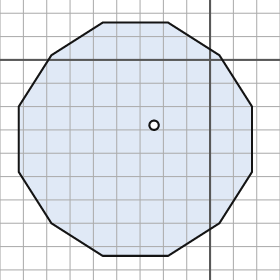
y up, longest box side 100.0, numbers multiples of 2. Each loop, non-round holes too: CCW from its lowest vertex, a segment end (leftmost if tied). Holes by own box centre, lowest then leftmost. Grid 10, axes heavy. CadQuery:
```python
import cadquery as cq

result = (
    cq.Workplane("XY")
    .moveTo(-46.0, -84.0)
    .lineTo(-18.0, -84.0)
    .lineTo(4.0, -70.0)
    .lineTo(18.0, -48.0)
    .lineTo(18.0, -20.0)
    .lineTo(4.0, 2.0)
    .lineTo(-18.0, 16.0)
    .lineTo(-46.0, 16.0)
    .lineTo(-68.0, 2.0)
    .lineTo(-82.0, -20.0)
    .lineTo(-82.0, -48.0)
    .lineTo(-68.0, -70.0)
    .close()
    .moveTo(-24.0, -28.0)
    .circle(2.0)
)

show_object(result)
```